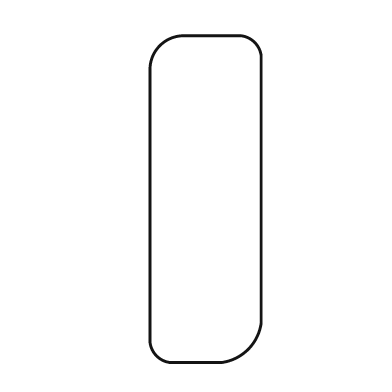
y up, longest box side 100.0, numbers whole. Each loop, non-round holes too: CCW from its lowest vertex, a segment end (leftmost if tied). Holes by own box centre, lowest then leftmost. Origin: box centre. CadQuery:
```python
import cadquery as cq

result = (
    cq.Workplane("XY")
    .moveTo(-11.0, -50.0)
    .lineTo(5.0, -50.0)
    .threePointArc((13.0, -46.0), (17.0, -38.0))
    .lineTo(17.0, 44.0)
    .threePointArc((15.0, 48.0), (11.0, 50.0))
    .lineTo(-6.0, 50.0)
    .threePointArc((-14.0, 47.0), (-17.0, 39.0))
    .lineTo(-17.0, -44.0)
    .threePointArc((-15.0, -48.0), (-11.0, -50.0))
    .close()
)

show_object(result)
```